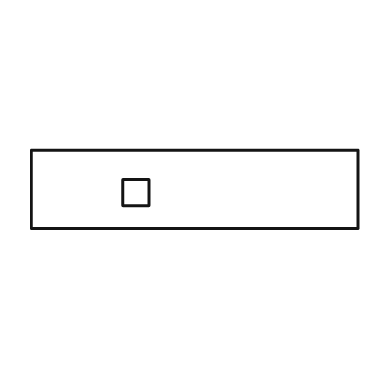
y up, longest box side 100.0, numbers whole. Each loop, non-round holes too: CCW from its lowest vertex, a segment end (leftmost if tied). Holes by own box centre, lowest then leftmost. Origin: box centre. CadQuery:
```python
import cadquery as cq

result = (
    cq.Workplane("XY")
    .moveTo(-50.0, -12.0)
    .lineTo(50.0, -12.0)
    .lineTo(50.0, 12.0)
    .lineTo(-50.0, 12.0)
    .close()
    .moveTo(-22.0, -5.0)
    .lineTo(-14.0, -5.0)
    .lineTo(-14.0, 3.0)
    .lineTo(-22.0, 3.0)
    .close()
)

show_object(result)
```